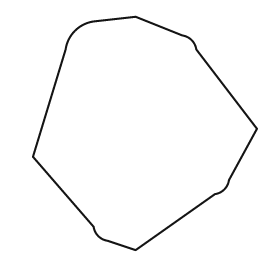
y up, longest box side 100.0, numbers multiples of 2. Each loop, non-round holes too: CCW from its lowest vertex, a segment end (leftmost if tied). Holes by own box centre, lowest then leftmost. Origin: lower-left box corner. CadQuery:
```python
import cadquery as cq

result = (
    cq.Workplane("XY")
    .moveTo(44.0, 0.0)
    .lineTo(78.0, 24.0)
    .threePointArc((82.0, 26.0), (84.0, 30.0))
    .lineTo(96.0, 52.0)
    .lineTo(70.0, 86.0)
    .threePointArc((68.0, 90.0), (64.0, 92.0))
    .lineTo(44.0, 100.0)
    .lineTo(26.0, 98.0)
    .threePointArc((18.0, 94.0), (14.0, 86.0))
    .lineTo(0.0, 40.0)
    .lineTo(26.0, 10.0)
    .threePointArc((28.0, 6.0), (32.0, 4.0))
    .close()
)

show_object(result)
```